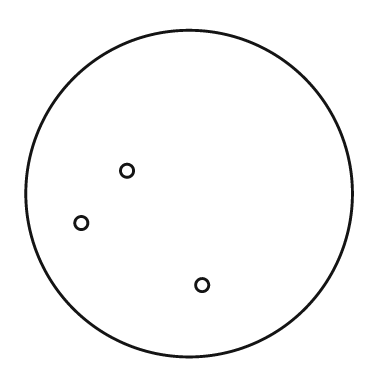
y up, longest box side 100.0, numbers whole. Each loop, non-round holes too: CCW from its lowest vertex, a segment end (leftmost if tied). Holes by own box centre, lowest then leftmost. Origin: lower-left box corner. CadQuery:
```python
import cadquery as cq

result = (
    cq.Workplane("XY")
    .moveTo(50.0, 50.0)
    .circle(50.0)
    .moveTo(54.0, 22.0)
    .circle(2.0)
    .moveTo(17.0, 41.0)
    .circle(2.0)
    .moveTo(31.0, 57.0)
    .circle(2.0)
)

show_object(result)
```